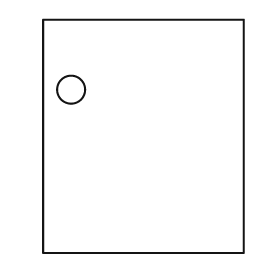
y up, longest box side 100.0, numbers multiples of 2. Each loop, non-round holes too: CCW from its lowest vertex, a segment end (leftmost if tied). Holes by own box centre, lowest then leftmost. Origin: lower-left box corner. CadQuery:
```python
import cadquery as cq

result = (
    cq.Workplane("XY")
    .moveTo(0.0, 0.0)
    .lineTo(86.0, 0.0)
    .lineTo(86.0, 100.0)
    .lineTo(0.0, 100.0)
    .close()
    .moveTo(12.0, 70.0)
    .circle(6.0)
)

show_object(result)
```